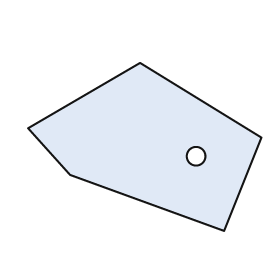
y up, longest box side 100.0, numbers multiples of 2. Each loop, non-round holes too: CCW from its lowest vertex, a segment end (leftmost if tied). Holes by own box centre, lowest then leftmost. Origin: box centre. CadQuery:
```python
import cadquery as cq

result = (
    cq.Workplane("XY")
    .moveTo(34.0, -36.0)
    .lineTo(50.0, 4.0)
    .lineTo(-2.0, 36.0)
    .lineTo(-50.0, 8.0)
    .lineTo(-32.0, -12.0)
    .close()
    .moveTo(22.0, -4.0)
    .circle(4.0)
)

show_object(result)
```